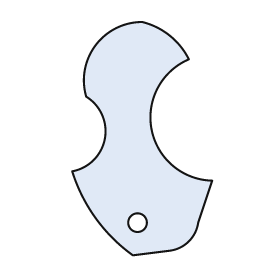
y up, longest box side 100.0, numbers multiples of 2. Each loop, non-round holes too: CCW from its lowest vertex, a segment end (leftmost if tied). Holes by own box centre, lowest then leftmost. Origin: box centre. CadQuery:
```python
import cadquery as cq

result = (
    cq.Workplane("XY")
    .moveTo(-4.0, -50.0)
    .lineTo(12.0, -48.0)
    .threePointArc((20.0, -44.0), (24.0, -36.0))
    .lineTo(30.0, -18.0)
    .threePointArc((4.0, 4.0), (20.0, 34.0))
    .threePointArc((12.0, 44.0), (0.0, 50.0))
    .threePointArc((-20.0, 40.0), (-24.0, 18.0))
    .threePointArc((-16.0, 0.0), (-30.0, -14.0))
    .threePointArc((-20.0, -34.0), (-4.0, -50.0))
    .close()
    .moveTo(-2.0, -36.0)
    .circle(4.0)
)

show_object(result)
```